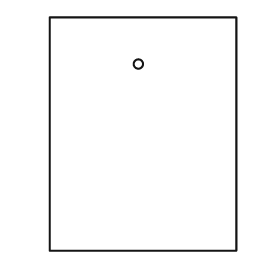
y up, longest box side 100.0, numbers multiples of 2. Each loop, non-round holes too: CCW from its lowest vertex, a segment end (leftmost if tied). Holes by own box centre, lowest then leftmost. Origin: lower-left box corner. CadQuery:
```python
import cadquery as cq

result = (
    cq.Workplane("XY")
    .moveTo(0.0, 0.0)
    .lineTo(80.0, 0.0)
    .lineTo(80.0, 100.0)
    .lineTo(0.0, 100.0)
    .close()
    .moveTo(38.0, 80.0)
    .circle(2.0)
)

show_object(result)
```